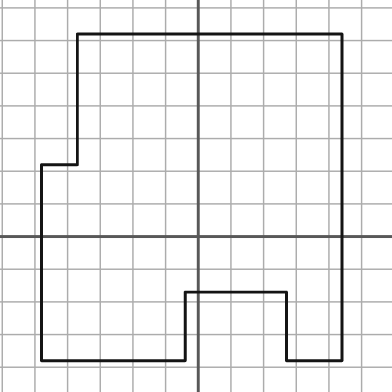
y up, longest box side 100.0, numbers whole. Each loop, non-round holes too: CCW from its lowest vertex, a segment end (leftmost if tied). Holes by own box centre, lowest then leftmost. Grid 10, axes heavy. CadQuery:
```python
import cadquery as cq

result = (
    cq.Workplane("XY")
    .moveTo(-48.0, -38.0)
    .lineTo(-4.0, -38.0)
    .lineTo(-4.0, -17.0)
    .lineTo(27.0, -17.0)
    .lineTo(27.0, -38.0)
    .lineTo(44.0, -38.0)
    .lineTo(44.0, 62.0)
    .lineTo(-37.0, 62.0)
    .lineTo(-37.0, 22.0)
    .lineTo(-48.0, 22.0)
    .close()
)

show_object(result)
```